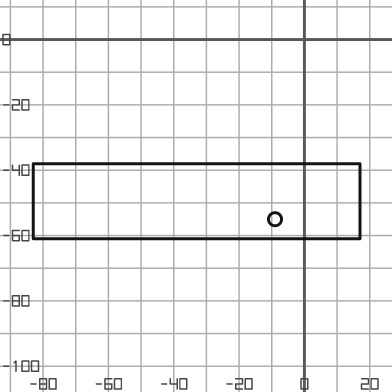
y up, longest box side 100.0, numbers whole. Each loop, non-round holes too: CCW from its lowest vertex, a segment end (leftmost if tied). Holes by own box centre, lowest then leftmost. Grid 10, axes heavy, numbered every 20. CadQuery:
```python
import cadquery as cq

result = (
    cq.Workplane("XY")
    .moveTo(-83.0, -61.0)
    .lineTo(17.0, -61.0)
    .lineTo(17.0, -38.0)
    .lineTo(-83.0, -38.0)
    .close()
    .moveTo(-9.0, -55.0)
    .circle(2.0)
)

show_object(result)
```